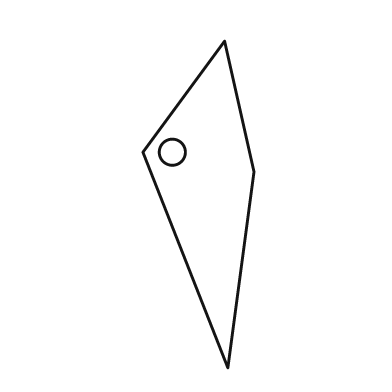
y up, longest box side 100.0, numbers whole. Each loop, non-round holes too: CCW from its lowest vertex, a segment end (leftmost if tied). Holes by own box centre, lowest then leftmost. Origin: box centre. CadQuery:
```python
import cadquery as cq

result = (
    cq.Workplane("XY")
    .moveTo(9.0, -50.0)
    .lineTo(17.0, 10.0)
    .lineTo(8.0, 50.0)
    .lineTo(-17.0, 16.0)
    .close()
    .moveTo(-8.0, 16.0)
    .circle(4.0)
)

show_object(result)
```